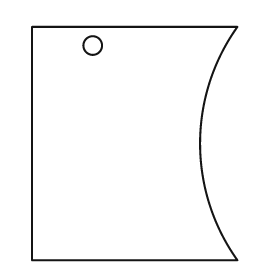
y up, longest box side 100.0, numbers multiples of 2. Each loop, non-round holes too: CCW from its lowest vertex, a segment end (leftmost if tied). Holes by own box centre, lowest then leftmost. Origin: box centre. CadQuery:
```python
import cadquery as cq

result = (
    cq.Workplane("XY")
    .moveTo(-44.0, -50.0)
    .lineTo(44.0, -50.0)
    .threePointArc((28.0, 0.0), (44.0, 50.0))
    .lineTo(-44.0, 50.0)
    .close()
    .moveTo(-18.0, 42.0)
    .circle(4.0)
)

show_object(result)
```